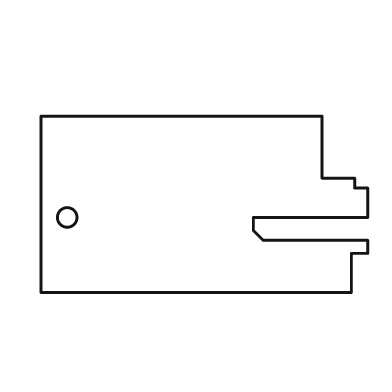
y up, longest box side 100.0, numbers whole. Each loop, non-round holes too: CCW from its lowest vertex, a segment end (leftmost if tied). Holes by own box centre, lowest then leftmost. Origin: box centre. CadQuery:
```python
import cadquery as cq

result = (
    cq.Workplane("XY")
    .moveTo(-50.0, -27.0)
    .lineTo(45.0, -27.0)
    .lineTo(45.0, -15.0)
    .lineTo(50.0, -15.0)
    .lineTo(50.0, -11.0)
    .lineTo(18.0, -11.0)
    .lineTo(15.0, -8.0)
    .lineTo(15.0, -4.0)
    .lineTo(50.0, -4.0)
    .lineTo(50.0, 5.0)
    .lineTo(46.0, 5.0)
    .lineTo(46.0, 8.0)
    .lineTo(36.0, 8.0)
    .lineTo(36.0, 27.0)
    .lineTo(-50.0, 27.0)
    .close()
    .moveTo(-42.0, -4.0)
    .circle(3.0)
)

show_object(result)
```